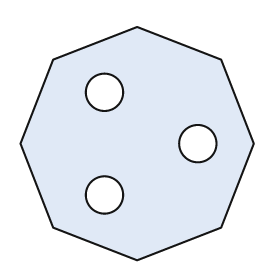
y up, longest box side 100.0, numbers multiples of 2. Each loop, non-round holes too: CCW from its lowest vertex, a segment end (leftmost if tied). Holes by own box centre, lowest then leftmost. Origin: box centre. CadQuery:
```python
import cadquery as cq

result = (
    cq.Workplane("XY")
    .moveTo(0.0, -50.0)
    .lineTo(36.0, -36.0)
    .lineTo(50.0, 0.0)
    .lineTo(36.0, 36.0)
    .lineTo(0.0, 50.0)
    .lineTo(-36.0, 36.0)
    .lineTo(-50.0, 0.0)
    .lineTo(-36.0, -36.0)
    .close()
    .moveTo(-14.0, -22.0)
    .circle(8.0)
    .moveTo(26.0, 0.0)
    .circle(8.0)
    .moveTo(-14.0, 22.0)
    .circle(8.0)
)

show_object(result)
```